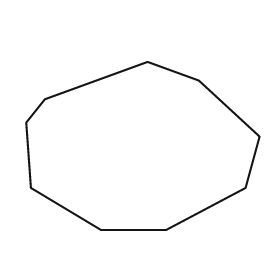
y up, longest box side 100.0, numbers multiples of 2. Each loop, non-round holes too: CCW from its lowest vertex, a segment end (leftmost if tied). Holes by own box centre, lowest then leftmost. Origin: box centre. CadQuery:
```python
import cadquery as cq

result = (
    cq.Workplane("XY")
    .moveTo(-18.0, -36.0)
    .lineTo(10.0, -36.0)
    .lineTo(44.0, -18.0)
    .lineTo(50.0, 4.0)
    .lineTo(24.0, 28.0)
    .lineTo(2.0, 36.0)
    .lineTo(-42.0, 20.0)
    .lineTo(-50.0, 10.0)
    .lineTo(-48.0, -18.0)
    .close()
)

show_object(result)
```